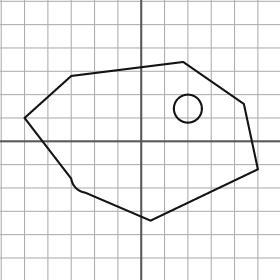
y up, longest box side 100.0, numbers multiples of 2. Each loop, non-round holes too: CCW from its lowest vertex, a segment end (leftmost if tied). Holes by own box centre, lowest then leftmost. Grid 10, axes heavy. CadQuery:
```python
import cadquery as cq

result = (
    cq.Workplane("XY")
    .moveTo(4.0, -34.0)
    .lineTo(50.0, -12.0)
    .lineTo(44.0, 16.0)
    .lineTo(18.0, 34.0)
    .lineTo(-30.0, 28.0)
    .lineTo(-50.0, 10.0)
    .lineTo(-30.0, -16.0)
    .threePointArc((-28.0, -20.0), (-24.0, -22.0))
    .close()
    .moveTo(20.0, 14.0)
    .circle(6.0)
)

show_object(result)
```